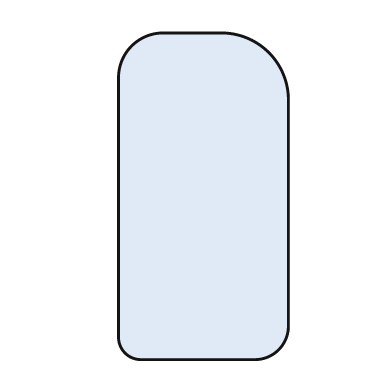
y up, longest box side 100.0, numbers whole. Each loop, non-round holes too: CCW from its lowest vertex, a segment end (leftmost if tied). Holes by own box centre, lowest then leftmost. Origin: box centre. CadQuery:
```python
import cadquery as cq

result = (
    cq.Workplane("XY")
    .moveTo(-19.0, -50.0)
    .lineTo(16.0, -50.0)
    .threePointArc((23.0, -47.0), (26.0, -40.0))
    .lineTo(26.0, 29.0)
    .threePointArc((20.0, 44.0), (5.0, 50.0))
    .lineTo(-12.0, 50.0)
    .threePointArc((-22.0, 46.0), (-26.0, 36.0))
    .lineTo(-26.0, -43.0)
    .threePointArc((-24.0, -48.0), (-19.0, -50.0))
    .close()
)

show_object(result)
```